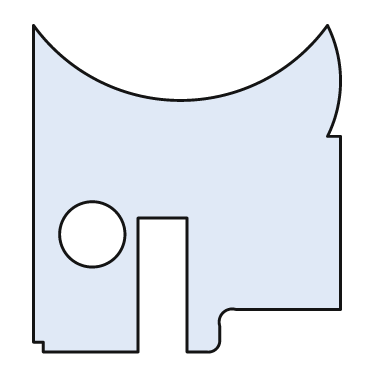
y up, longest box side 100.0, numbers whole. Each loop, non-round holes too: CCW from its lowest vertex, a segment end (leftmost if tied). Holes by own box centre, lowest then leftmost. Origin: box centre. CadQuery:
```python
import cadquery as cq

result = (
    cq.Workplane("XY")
    .moveTo(-44.0, -50.0)
    .lineTo(-15.0, -50.0)
    .lineTo(-15.0, -9.0)
    .lineTo(0.0, -9.0)
    .lineTo(0.0, -50.0)
    .lineTo(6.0, -50.0)
    .threePointArc((9.0, -49.0), (10.0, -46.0))
    .lineTo(10.0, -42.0)
    .threePointArc((11.0, -38.0), (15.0, -37.0))
    .lineTo(47.0, -37.0)
    .lineTo(47.0, 16.0)
    .lineTo(43.0, 16.0)
    .threePointArc((47.0, 33.0), (43.0, 50.0))
    .threePointArc((-2.0, 27.0), (-47.0, 50.0))
    .lineTo(-47.0, -47.0)
    .lineTo(-44.0, -47.0)
    .close()
    .moveTo(-29.0, -14.0)
    .circle(10.0)
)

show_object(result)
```